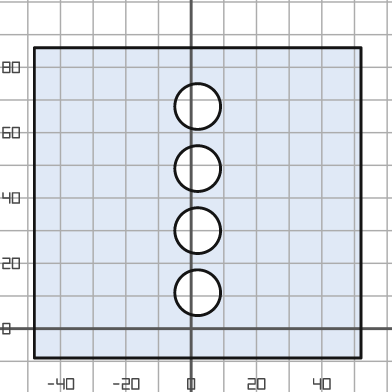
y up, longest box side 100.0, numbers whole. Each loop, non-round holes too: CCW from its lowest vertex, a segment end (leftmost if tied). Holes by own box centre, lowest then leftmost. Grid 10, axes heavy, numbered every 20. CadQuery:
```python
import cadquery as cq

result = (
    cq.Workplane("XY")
    .moveTo(-48.0, -9.0)
    .lineTo(52.0, -9.0)
    .lineTo(52.0, 86.0)
    .lineTo(-48.0, 86.0)
    .close()
    .moveTo(2.0, 11.0)
    .circle(7.0)
    .moveTo(2.0, 30.0)
    .circle(7.0)
    .moveTo(2.0, 49.0)
    .circle(7.0)
    .moveTo(2.0, 68.0)
    .circle(7.0)
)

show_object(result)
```